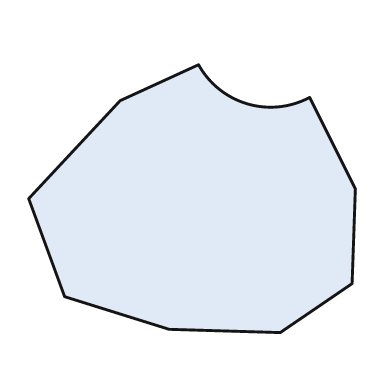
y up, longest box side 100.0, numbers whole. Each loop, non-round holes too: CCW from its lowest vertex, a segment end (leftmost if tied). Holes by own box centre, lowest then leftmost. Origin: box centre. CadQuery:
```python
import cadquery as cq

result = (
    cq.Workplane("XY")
    .moveTo(27.0, -41.0)
    .lineTo(49.0, -26.0)
    .lineTo(50.0, 3.0)
    .lineTo(36.0, 31.0)
    .threePointArc((17.0, 29.0), (2.0, 41.0))
    .lineTo(-22.0, 30.0)
    .lineTo(-50.0, 0.0)
    .lineTo(-39.0, -30.0)
    .lineTo(-7.0, -40.0)
    .close()
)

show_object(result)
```